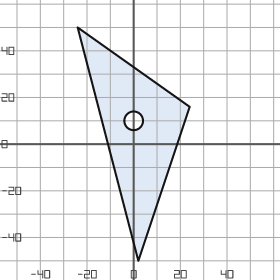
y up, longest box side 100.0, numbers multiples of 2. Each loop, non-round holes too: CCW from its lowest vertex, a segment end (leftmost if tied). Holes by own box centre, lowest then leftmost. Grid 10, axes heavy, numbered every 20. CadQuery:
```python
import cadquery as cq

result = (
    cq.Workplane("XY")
    .moveTo(2.0, -50.0)
    .lineTo(24.0, 16.0)
    .lineTo(-24.0, 50.0)
    .close()
    .moveTo(0.0, 10.0)
    .circle(4.0)
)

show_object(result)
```